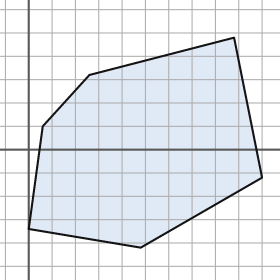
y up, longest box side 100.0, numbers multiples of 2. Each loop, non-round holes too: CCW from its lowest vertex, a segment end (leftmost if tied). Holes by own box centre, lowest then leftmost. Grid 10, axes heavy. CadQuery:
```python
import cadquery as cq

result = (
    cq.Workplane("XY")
    .moveTo(48.0, -42.0)
    .lineTo(100.0, -12.0)
    .lineTo(88.0, 48.0)
    .lineTo(26.0, 32.0)
    .lineTo(6.0, 10.0)
    .lineTo(0.0, -34.0)
    .close()
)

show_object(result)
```